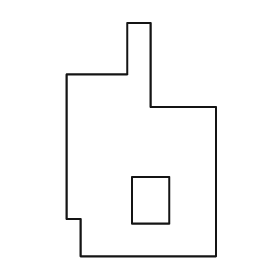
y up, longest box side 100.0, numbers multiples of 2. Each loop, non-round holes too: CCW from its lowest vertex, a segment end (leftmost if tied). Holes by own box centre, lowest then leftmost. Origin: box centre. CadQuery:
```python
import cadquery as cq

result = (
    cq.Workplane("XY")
    .moveTo(-26.0, -50.0)
    .lineTo(32.0, -50.0)
    .lineTo(32.0, 14.0)
    .lineTo(4.0, 14.0)
    .lineTo(4.0, 50.0)
    .lineTo(-6.0, 50.0)
    .lineTo(-6.0, 28.0)
    .lineTo(-32.0, 28.0)
    .lineTo(-32.0, -34.0)
    .lineTo(-26.0, -34.0)
    .close()
    .moveTo(-4.0, -36.0)
    .lineTo(12.0, -36.0)
    .lineTo(12.0, -16.0)
    .lineTo(-4.0, -16.0)
    .close()
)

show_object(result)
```